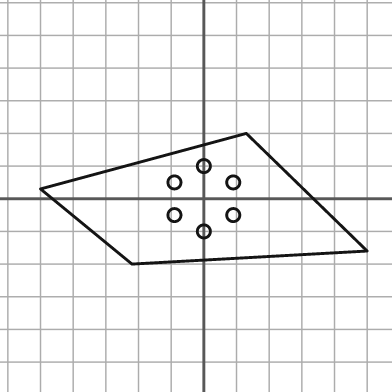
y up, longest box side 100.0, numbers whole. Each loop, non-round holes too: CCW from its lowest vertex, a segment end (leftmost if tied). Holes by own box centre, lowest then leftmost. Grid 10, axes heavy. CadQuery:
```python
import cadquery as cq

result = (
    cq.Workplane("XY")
    .moveTo(-22.0, -20.0)
    .lineTo(50.0, -16.0)
    .lineTo(13.0, 20.0)
    .lineTo(-50.0, 3.0)
    .close()
    .moveTo(0.0, -10.0)
    .circle(2.0)
    .moveTo(-9.0, -5.0)
    .circle(2.0)
    .moveTo(9.0, -5.0)
    .circle(2.0)
    .moveTo(-9.0, 5.0)
    .circle(2.0)
    .moveTo(9.0, 5.0)
    .circle(2.0)
    .moveTo(0.0, 10.0)
    .circle(2.0)
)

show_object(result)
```